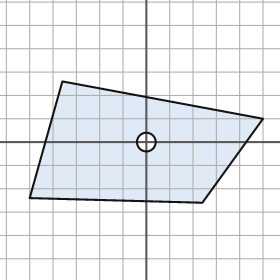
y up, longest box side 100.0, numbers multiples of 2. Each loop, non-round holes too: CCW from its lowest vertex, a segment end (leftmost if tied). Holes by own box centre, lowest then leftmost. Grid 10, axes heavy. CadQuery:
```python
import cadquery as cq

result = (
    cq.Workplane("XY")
    .moveTo(24.0, -26.0)
    .lineTo(50.0, 10.0)
    .lineTo(-36.0, 26.0)
    .lineTo(-50.0, -24.0)
    .close()
    .moveTo(0.0, 0.0)
    .circle(4.0)
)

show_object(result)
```